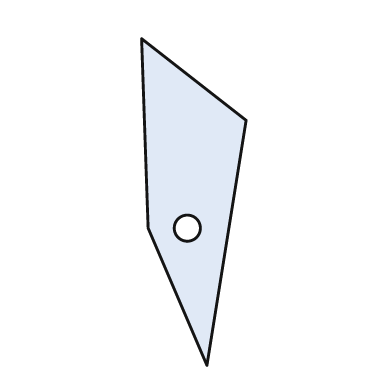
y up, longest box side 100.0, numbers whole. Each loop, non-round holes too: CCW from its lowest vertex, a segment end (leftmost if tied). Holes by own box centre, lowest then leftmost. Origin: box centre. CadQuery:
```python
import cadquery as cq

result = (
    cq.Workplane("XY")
    .moveTo(4.0, -50.0)
    .lineTo(16.0, 25.0)
    .lineTo(-16.0, 50.0)
    .lineTo(-14.0, -8.0)
    .close()
    .moveTo(-2.0, -8.0)
    .circle(4.0)
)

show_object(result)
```